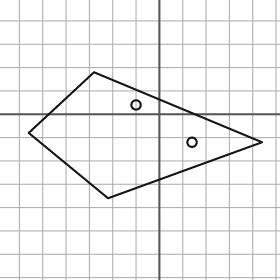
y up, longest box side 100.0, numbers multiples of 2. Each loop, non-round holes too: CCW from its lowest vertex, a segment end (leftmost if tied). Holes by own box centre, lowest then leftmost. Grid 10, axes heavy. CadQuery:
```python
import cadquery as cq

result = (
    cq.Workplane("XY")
    .moveTo(-22.0, -36.0)
    .lineTo(44.0, -12.0)
    .lineTo(-28.0, 18.0)
    .lineTo(-56.0, -8.0)
    .close()
    .moveTo(14.0, -12.0)
    .circle(2.0)
    .moveTo(-10.0, 4.0)
    .circle(2.0)
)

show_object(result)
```